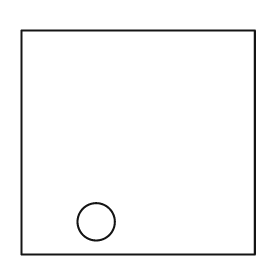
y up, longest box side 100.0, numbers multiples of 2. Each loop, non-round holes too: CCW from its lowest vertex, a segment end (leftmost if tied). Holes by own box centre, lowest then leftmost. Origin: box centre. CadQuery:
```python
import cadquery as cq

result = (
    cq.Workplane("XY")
    .moveTo(-50.0, -48.0)
    .lineTo(50.0, -48.0)
    .lineTo(50.0, 48.0)
    .lineTo(-50.0, 48.0)
    .close()
    .moveTo(-18.0, -34.0)
    .circle(8.0)
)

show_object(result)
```